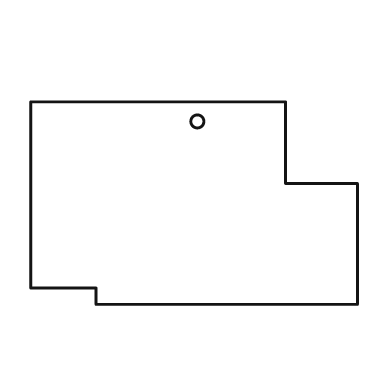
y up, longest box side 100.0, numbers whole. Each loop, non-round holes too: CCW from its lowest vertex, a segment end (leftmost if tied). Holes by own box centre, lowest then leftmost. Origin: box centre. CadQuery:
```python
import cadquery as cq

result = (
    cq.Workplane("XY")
    .moveTo(-30.0, -31.0)
    .lineTo(50.0, -31.0)
    .lineTo(50.0, 6.0)
    .lineTo(28.0, 6.0)
    .lineTo(28.0, 31.0)
    .lineTo(-50.0, 31.0)
    .lineTo(-50.0, -26.0)
    .lineTo(-30.0, -26.0)
    .close()
    .moveTo(1.0, 25.0)
    .circle(2.0)
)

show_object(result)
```